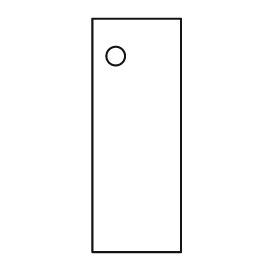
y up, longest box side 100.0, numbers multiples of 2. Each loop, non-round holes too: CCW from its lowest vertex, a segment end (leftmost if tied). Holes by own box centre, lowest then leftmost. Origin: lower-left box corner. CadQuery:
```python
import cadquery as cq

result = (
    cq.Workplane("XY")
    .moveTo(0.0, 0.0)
    .lineTo(38.0, 0.0)
    .lineTo(38.0, 100.0)
    .lineTo(0.0, 100.0)
    .close()
    .moveTo(10.0, 84.0)
    .circle(4.0)
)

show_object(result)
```